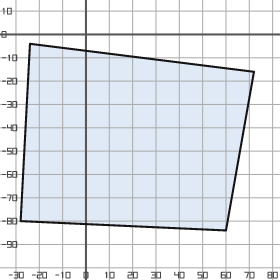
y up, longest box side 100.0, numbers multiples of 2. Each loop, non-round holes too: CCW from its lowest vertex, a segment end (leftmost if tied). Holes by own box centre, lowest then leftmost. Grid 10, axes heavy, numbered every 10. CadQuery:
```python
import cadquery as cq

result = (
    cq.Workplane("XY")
    .moveTo(60.0, -84.0)
    .lineTo(72.0, -16.0)
    .lineTo(-24.0, -4.0)
    .lineTo(-28.0, -80.0)
    .close()
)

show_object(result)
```